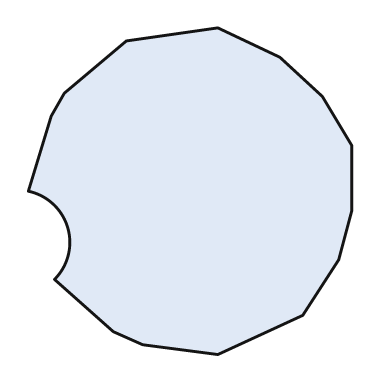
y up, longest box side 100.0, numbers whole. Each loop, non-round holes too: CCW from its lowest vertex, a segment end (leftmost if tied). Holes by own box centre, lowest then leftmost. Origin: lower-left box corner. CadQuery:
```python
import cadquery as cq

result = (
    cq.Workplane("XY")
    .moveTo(58.0, 0.0)
    .lineTo(84.0, 12.0)
    .lineTo(95.0, 29.0)
    .lineTo(99.0, 44.0)
    .lineTo(99.0, 64.0)
    .lineTo(90.0, 79.0)
    .lineTo(77.0, 91.0)
    .lineTo(58.0, 100.0)
    .lineTo(30.0, 96.0)
    .lineTo(11.0, 80.0)
    .lineTo(7.0, 73.0)
    .lineTo(0.0, 50.0)
    .threePointArc((12.0, 39.0), (8.0, 23.0))
    .lineTo(26.0, 7.0)
    .lineTo(35.0, 3.0)
    .close()
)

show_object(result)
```